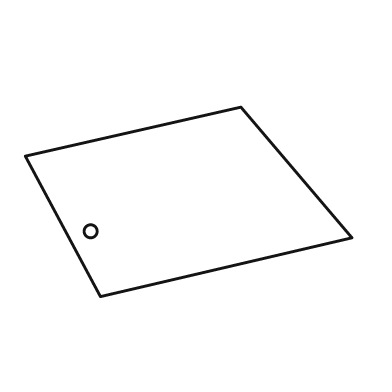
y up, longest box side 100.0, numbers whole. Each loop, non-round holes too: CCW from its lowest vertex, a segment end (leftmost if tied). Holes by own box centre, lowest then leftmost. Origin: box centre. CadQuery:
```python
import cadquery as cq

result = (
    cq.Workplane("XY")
    .moveTo(-27.0, -29.0)
    .lineTo(50.0, -11.0)
    .lineTo(16.0, 29.0)
    .lineTo(-50.0, 14.0)
    .close()
    .moveTo(-30.0, -9.0)
    .circle(2.0)
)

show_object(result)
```